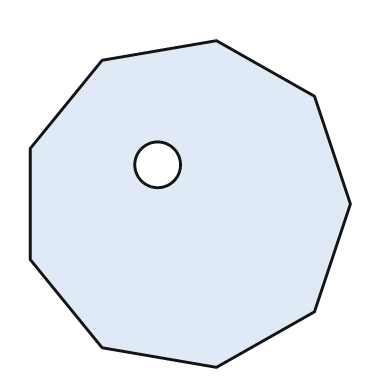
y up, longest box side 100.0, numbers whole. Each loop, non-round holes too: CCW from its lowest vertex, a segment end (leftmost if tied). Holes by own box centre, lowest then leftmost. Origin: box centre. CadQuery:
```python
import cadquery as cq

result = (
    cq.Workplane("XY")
    .moveTo(8.0, -50.0)
    .lineTo(38.0, -33.0)
    .lineTo(49.0, 0.0)
    .lineTo(38.0, 33.0)
    .lineTo(8.0, 50.0)
    .lineTo(-27.0, 44.0)
    .lineTo(-49.0, 17.0)
    .lineTo(-49.0, -17.0)
    .lineTo(-27.0, -44.0)
    .close()
    .moveTo(-10.0, 12.0)
    .circle(7.0)
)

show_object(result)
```